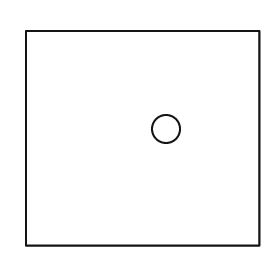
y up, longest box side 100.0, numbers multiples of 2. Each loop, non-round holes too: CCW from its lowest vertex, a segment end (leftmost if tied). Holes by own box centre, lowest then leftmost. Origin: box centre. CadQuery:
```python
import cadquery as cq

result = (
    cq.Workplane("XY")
    .moveTo(-50.0, -46.0)
    .lineTo(50.0, -46.0)
    .lineTo(50.0, 46.0)
    .lineTo(-50.0, 46.0)
    .close()
    .moveTo(10.0, 4.0)
    .circle(6.0)
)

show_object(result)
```